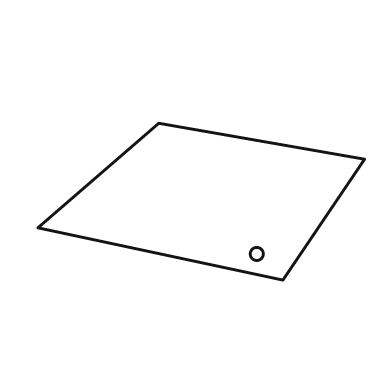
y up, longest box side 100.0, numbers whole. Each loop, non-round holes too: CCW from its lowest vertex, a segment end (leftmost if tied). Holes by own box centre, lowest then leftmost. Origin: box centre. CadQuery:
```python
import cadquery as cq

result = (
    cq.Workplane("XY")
    .moveTo(25.0, -24.0)
    .lineTo(50.0, 13.0)
    .lineTo(-13.0, 24.0)
    .lineTo(-50.0, -8.0)
    .close()
    .moveTo(17.0, -16.0)
    .circle(2.0)
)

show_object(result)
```